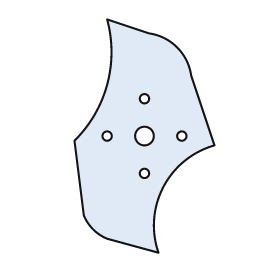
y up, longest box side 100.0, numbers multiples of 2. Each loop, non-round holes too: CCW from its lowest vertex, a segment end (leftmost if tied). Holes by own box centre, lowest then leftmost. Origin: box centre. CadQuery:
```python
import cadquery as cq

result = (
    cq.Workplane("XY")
    .moveTo(6.0, -50.0)
    .threePointArc((8.0, -22.0), (30.0, -4.0))
    .lineTo(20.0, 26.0)
    .threePointArc((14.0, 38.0), (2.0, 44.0))
    .lineTo(-16.0, 50.0)
    .threePointArc((-16.0, 22.0), (-30.0, -2.0))
    .lineTo(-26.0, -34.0)
    .threePointArc((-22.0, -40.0), (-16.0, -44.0))
    .close()
    .moveTo(0.0, -16.0)
    .circle(2.0)
    .moveTo(-16.0, 0.0)
    .circle(2.0)
    .moveTo(0.0, 0.0)
    .circle(4.0)
    .moveTo(16.0, 0.0)
    .circle(2.0)
    .moveTo(0.0, 16.0)
    .circle(2.0)
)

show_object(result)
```